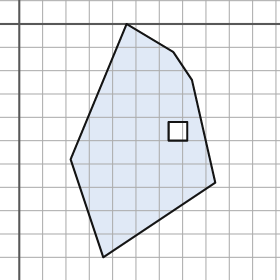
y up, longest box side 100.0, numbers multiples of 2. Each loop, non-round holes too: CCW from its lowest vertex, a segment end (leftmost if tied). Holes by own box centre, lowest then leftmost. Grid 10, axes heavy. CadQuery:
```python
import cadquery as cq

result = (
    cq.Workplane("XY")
    .moveTo(36.0, -100.0)
    .lineTo(84.0, -68.0)
    .lineTo(74.0, -24.0)
    .lineTo(66.0, -12.0)
    .lineTo(46.0, 0.0)
    .lineTo(22.0, -58.0)
    .close()
    .moveTo(64.0, -50.0)
    .lineTo(72.0, -50.0)
    .lineTo(72.0, -42.0)
    .lineTo(64.0, -42.0)
    .close()
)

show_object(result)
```